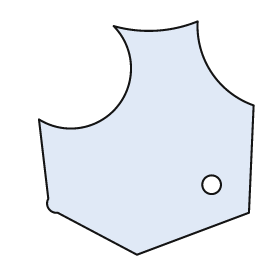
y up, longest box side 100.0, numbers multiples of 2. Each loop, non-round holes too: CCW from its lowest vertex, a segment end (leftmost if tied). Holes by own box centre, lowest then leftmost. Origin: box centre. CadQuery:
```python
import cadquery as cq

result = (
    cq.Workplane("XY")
    .moveTo(-4.0, -50.0)
    .lineTo(44.0, -32.0)
    .lineTo(46.0, 14.0)
    .threePointArc((28.0, 28.0), (22.0, 50.0))
    .threePointArc((4.0, 46.0), (-14.0, 48.0))
    .threePointArc((-12.0, 14.0), (-46.0, 8.0))
    .lineTo(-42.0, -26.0)
    .threePointArc((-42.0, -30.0), (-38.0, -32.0))
    .close()
    .moveTo(28.0, -20.0)
    .circle(4.0)
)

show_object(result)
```